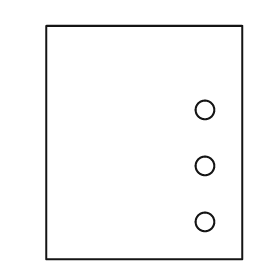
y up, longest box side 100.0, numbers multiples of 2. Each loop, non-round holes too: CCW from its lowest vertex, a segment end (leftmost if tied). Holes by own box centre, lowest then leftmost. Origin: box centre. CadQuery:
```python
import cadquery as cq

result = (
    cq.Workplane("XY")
    .moveTo(-42.0, -50.0)
    .lineTo(42.0, -50.0)
    .lineTo(42.0, 50.0)
    .lineTo(-42.0, 50.0)
    .close()
    .moveTo(26.0, -34.0)
    .circle(4.0)
    .moveTo(26.0, -10.0)
    .circle(4.0)
    .moveTo(26.0, 14.0)
    .circle(4.0)
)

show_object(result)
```